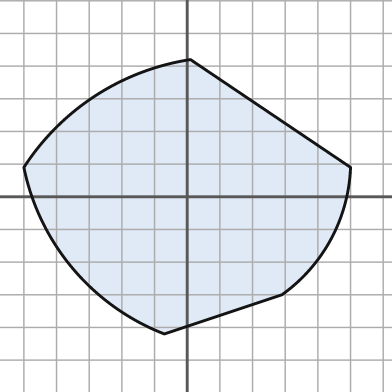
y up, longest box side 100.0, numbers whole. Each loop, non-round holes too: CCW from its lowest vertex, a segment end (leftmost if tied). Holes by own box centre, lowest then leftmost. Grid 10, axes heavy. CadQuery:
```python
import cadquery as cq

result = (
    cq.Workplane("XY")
    .moveTo(-7.0, -42.0)
    .lineTo(29.0, -30.0)
    .threePointArc((44.0, -13.0), (50.0, 9.0))
    .lineTo(1.0, 42.0)
    .threePointArc((-28.0, 31.0), (-50.0, 9.0))
    .threePointArc((-35.0, -22.0), (-7.0, -42.0))
    .close()
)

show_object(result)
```